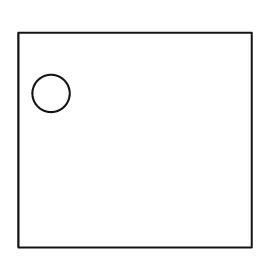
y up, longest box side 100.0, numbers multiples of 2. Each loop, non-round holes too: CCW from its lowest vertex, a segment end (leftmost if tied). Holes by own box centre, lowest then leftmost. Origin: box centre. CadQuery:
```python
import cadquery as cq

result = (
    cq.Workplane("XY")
    .moveTo(-50.0, -46.0)
    .lineTo(50.0, -46.0)
    .lineTo(50.0, 46.0)
    .lineTo(-50.0, 46.0)
    .close()
    .moveTo(-36.0, 20.0)
    .circle(8.0)
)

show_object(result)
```